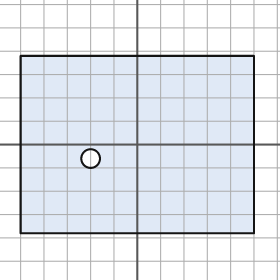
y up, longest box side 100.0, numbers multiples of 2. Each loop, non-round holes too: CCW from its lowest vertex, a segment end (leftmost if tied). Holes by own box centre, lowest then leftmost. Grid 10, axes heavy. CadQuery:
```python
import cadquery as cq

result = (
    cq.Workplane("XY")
    .moveTo(-50.0, -38.0)
    .lineTo(50.0, -38.0)
    .lineTo(50.0, 38.0)
    .lineTo(-50.0, 38.0)
    .close()
    .moveTo(-20.0, -6.0)
    .circle(4.0)
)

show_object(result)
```